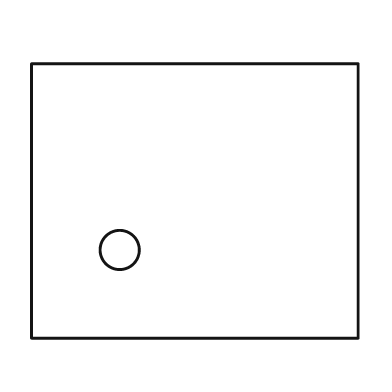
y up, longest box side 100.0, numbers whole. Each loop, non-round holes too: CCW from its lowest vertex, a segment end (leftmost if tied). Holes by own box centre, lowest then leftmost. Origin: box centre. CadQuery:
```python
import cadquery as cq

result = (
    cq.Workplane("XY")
    .moveTo(-50.0, -42.0)
    .lineTo(50.0, -42.0)
    .lineTo(50.0, 42.0)
    .lineTo(-50.0, 42.0)
    .close()
    .moveTo(-23.0, -15.0)
    .circle(6.0)
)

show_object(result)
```